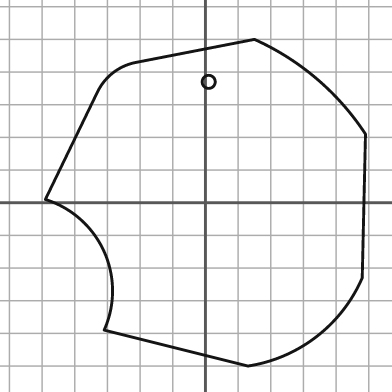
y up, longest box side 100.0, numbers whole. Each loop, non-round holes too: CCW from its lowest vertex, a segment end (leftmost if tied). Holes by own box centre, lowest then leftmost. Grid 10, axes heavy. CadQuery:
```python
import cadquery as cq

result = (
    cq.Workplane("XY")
    .moveTo(13.0, -50.0)
    .threePointArc((34.0, -41.0), (48.0, -23.0))
    .lineTo(49.0, 21.0)
    .threePointArc((34.0, 38.0), (15.0, 50.0))
    .lineTo(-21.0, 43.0)
    .threePointArc((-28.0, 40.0), (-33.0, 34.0))
    .lineTo(-49.0, 1.0)
    .threePointArc((-31.0, -15.0), (-31.0, -39.0))
    .close()
    .moveTo(1.0, 37.0)
    .circle(2.0)
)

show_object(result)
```